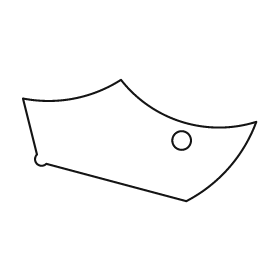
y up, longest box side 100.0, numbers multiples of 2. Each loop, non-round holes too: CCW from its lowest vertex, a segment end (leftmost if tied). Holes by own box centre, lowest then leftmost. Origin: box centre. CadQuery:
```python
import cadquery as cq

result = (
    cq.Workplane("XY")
    .moveTo(20.0, -26.0)
    .threePointArc((38.0, -12.0), (50.0, 8.0))
    .threePointArc((18.0, 8.0), (-8.0, 26.0))
    .threePointArc((-28.0, 18.0), (-50.0, 18.0))
    .lineTo(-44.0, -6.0)
    .threePointArc((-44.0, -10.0), (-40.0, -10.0))
    .close()
    .moveTo(18.0, 0.0)
    .circle(4.0)
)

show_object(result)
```